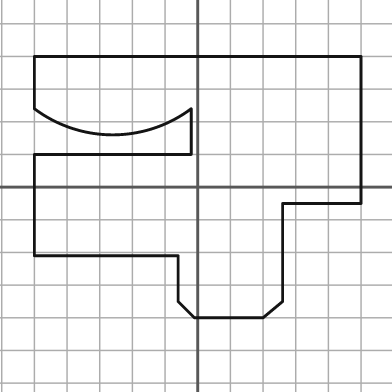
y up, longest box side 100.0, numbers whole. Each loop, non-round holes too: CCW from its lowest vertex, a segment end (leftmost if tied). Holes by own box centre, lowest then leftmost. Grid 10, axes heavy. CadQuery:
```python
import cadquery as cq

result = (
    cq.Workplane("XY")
    .moveTo(-1.0, -40.0)
    .lineTo(20.0, -40.0)
    .lineTo(26.0, -35.0)
    .lineTo(26.0, -5.0)
    .lineTo(50.0, -5.0)
    .lineTo(50.0, 40.0)
    .lineTo(-50.0, 40.0)
    .lineTo(-50.0, 24.0)
    .threePointArc((-26.0, 16.0), (-2.0, 24.0))
    .lineTo(-2.0, 10.0)
    .lineTo(-50.0, 10.0)
    .lineTo(-50.0, -21.0)
    .lineTo(-6.0, -21.0)
    .lineTo(-6.0, -35.0)
    .close()
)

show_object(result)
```